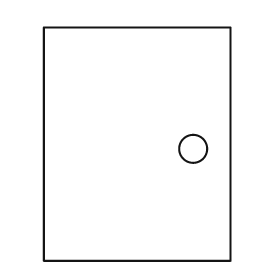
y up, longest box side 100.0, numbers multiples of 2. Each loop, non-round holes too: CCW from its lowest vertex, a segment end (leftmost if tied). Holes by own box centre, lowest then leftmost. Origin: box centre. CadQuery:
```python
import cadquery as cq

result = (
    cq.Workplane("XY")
    .moveTo(-40.0, -50.0)
    .lineTo(40.0, -50.0)
    .lineTo(40.0, 50.0)
    .lineTo(-40.0, 50.0)
    .close()
    .moveTo(24.0, -2.0)
    .circle(6.0)
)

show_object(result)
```